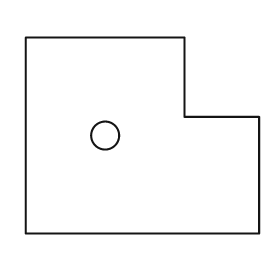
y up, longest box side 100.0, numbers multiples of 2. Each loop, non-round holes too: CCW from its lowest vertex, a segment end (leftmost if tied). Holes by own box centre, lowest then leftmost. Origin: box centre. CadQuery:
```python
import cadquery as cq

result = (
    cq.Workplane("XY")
    .moveTo(-50.0, -42.0)
    .lineTo(50.0, -42.0)
    .lineTo(50.0, 8.0)
    .lineTo(18.0, 8.0)
    .lineTo(18.0, 42.0)
    .lineTo(-50.0, 42.0)
    .close()
    .moveTo(-16.0, 0.0)
    .circle(6.0)
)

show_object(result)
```